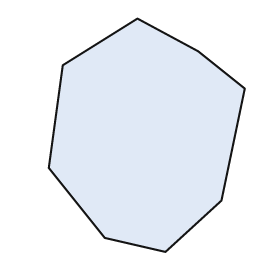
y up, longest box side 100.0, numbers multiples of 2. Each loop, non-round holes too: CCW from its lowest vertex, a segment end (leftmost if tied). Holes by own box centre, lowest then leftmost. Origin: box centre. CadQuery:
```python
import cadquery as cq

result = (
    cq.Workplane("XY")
    .moveTo(8.0, -50.0)
    .lineTo(32.0, -28.0)
    .lineTo(42.0, 20.0)
    .lineTo(22.0, 36.0)
    .lineTo(-4.0, 50.0)
    .lineTo(-36.0, 30.0)
    .lineTo(-42.0, -14.0)
    .lineTo(-18.0, -44.0)
    .close()
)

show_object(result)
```